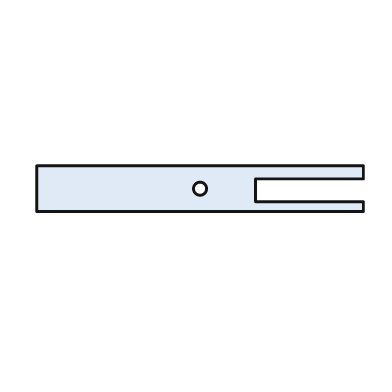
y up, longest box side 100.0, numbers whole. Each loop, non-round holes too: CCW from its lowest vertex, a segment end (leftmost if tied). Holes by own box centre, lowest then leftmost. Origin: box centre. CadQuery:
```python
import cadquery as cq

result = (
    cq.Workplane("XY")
    .moveTo(-50.0, -7.0)
    .lineTo(50.0, -7.0)
    .lineTo(50.0, -4.0)
    .lineTo(17.0, -4.0)
    .lineTo(17.0, 3.0)
    .lineTo(50.0, 3.0)
    .lineTo(50.0, 7.0)
    .lineTo(-50.0, 7.0)
    .close()
    .moveTo(0.0, 0.0)
    .circle(2.0)
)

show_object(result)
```